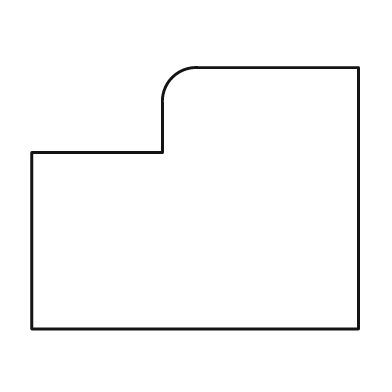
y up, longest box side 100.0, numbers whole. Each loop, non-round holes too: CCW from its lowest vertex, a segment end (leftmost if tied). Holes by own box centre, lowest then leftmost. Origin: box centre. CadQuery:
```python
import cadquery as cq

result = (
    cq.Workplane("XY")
    .moveTo(-50.0, -40.0)
    .lineTo(50.0, -40.0)
    .lineTo(50.0, 40.0)
    .lineTo(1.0, 40.0)
    .threePointArc((-7.0, 37.0), (-10.0, 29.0))
    .lineTo(-10.0, 14.0)
    .lineTo(-50.0, 14.0)
    .close()
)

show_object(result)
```